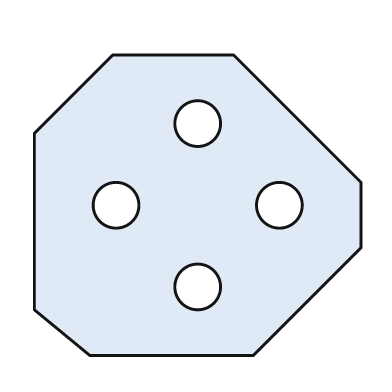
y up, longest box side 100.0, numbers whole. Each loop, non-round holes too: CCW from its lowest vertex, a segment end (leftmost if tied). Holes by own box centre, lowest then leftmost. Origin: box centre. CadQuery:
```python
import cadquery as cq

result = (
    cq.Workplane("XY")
    .moveTo(-33.0, -46.0)
    .lineTo(17.0, -46.0)
    .lineTo(50.0, -13.0)
    .lineTo(50.0, 7.0)
    .lineTo(11.0, 46.0)
    .lineTo(-26.0, 46.0)
    .lineTo(-50.0, 22.0)
    .lineTo(-50.0, -32.0)
    .close()
    .moveTo(0.0, -25.0)
    .circle(7.0)
    .moveTo(-25.0, 0.0)
    .circle(7.0)
    .moveTo(25.0, 0.0)
    .circle(7.0)
    .moveTo(0.0, 25.0)
    .circle(7.0)
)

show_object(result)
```